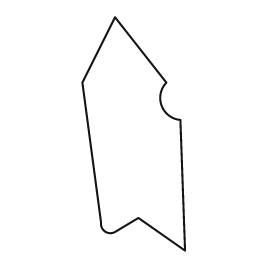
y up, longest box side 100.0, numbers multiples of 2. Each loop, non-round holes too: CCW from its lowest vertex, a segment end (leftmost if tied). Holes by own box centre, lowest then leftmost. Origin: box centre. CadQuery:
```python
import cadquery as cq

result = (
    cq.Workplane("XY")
    .moveTo(22.0, -50.0)
    .lineTo(20.0, 6.0)
    .threePointArc((12.0, 12.0), (14.0, 22.0))
    .lineTo(-8.0, 50.0)
    .lineTo(-22.0, 22.0)
    .lineTo(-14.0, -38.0)
    .threePointArc((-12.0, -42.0), (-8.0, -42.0))
    .lineTo(2.0, -36.0)
    .close()
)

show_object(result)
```